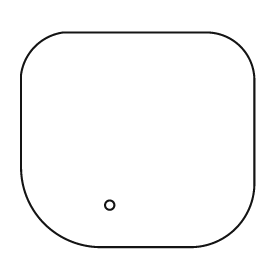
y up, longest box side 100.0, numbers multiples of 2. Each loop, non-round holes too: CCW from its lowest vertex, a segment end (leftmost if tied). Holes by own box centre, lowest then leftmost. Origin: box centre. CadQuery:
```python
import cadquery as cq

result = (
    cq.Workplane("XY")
    .moveTo(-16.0, -46.0)
    .lineTo(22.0, -46.0)
    .threePointArc((42.0, -38.0), (50.0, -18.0))
    .lineTo(50.0, 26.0)
    .threePointArc((44.0, 40.0), (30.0, 46.0))
    .lineTo(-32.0, 46.0)
    .threePointArc((-44.0, 40.0), (-50.0, 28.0))
    .lineTo(-50.0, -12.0)
    .threePointArc((-40.0, -36.0), (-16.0, -46.0))
    .close()
    .moveTo(-12.0, -28.0)
    .circle(2.0)
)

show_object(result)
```